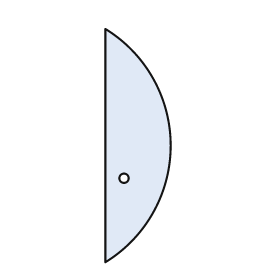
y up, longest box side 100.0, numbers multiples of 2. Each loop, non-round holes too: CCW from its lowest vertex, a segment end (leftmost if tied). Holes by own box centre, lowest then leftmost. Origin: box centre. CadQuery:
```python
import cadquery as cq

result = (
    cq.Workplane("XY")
    .moveTo(-14.0, -50.0)
    .threePointArc((14.0, 0.0), (-14.0, 50.0))
    .close()
    .moveTo(-6.0, -14.0)
    .circle(2.0)
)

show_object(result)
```